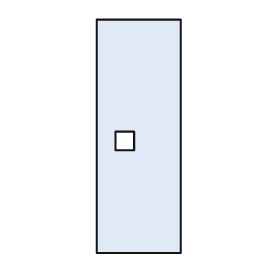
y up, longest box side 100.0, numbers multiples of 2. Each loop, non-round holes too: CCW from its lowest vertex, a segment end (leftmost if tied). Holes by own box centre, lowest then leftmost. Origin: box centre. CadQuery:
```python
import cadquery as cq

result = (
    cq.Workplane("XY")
    .moveTo(-18.0, -50.0)
    .lineTo(18.0, -50.0)
    .lineTo(18.0, 50.0)
    .lineTo(-18.0, 50.0)
    .close()
    .moveTo(-10.0, -6.0)
    .lineTo(-2.0, -6.0)
    .lineTo(-2.0, 2.0)
    .lineTo(-10.0, 2.0)
    .close()
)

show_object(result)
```